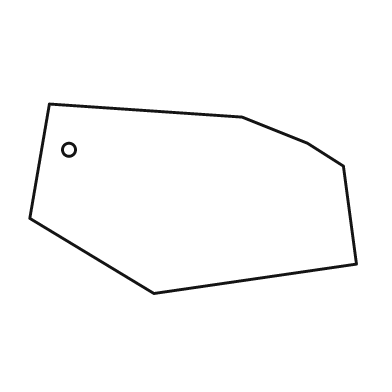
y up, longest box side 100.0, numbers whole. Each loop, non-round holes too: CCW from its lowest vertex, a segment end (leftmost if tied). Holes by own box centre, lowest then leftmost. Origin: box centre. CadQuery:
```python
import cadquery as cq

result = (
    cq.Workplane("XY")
    .moveTo(-12.0, -29.0)
    .lineTo(50.0, -20.0)
    .lineTo(46.0, 10.0)
    .lineTo(35.0, 17.0)
    .lineTo(15.0, 25.0)
    .lineTo(-44.0, 29.0)
    .lineTo(-50.0, -6.0)
    .close()
    .moveTo(-38.0, 15.0)
    .circle(2.0)
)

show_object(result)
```